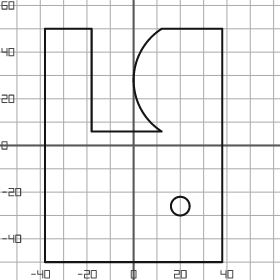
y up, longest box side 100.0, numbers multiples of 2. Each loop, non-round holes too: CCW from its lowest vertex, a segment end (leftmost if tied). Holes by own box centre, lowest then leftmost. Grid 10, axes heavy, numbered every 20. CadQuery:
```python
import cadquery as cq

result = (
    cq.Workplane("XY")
    .moveTo(-38.0, -50.0)
    .lineTo(38.0, -50.0)
    .lineTo(38.0, 50.0)
    .lineTo(12.0, 50.0)
    .threePointArc((0.0, 28.0), (12.0, 6.0))
    .lineTo(-18.0, 6.0)
    .lineTo(-18.0, 50.0)
    .lineTo(-38.0, 50.0)
    .close()
    .moveTo(20.0, -26.0)
    .circle(4.0)
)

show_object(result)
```